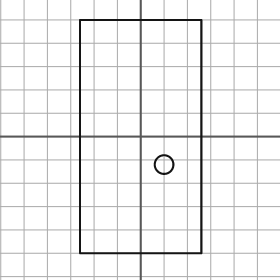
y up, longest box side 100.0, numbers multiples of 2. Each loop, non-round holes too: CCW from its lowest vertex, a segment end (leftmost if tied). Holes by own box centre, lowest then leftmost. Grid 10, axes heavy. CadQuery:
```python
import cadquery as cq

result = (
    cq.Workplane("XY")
    .moveTo(-26.0, -50.0)
    .lineTo(26.0, -50.0)
    .lineTo(26.0, 50.0)
    .lineTo(-26.0, 50.0)
    .close()
    .moveTo(10.0, -12.0)
    .circle(4.0)
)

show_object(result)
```